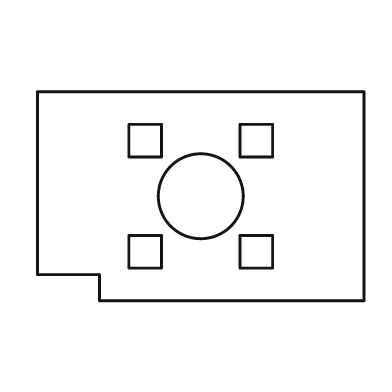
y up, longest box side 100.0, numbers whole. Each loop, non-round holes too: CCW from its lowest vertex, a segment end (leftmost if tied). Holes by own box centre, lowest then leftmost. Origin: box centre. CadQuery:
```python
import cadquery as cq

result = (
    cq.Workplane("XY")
    .moveTo(-31.0, -32.0)
    .lineTo(50.0, -32.0)
    .lineTo(50.0, 32.0)
    .lineTo(-50.0, 32.0)
    .lineTo(-50.0, -24.0)
    .lineTo(-31.0, -24.0)
    .close()
    .moveTo(-22.0, -22.0)
    .lineTo(-12.0, -22.0)
    .lineTo(-12.0, -12.0)
    .lineTo(-22.0, -12.0)
    .close()
    .moveTo(12.0, -22.0)
    .lineTo(22.0, -22.0)
    .lineTo(22.0, -12.0)
    .lineTo(12.0, -12.0)
    .close()
    .moveTo(0.0, 0.0)
    .circle(13.0)
    .moveTo(-22.0, 12.0)
    .lineTo(-12.0, 12.0)
    .lineTo(-12.0, 22.0)
    .lineTo(-22.0, 22.0)
    .close()
    .moveTo(12.0, 12.0)
    .lineTo(22.0, 12.0)
    .lineTo(22.0, 22.0)
    .lineTo(12.0, 22.0)
    .close()
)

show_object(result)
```